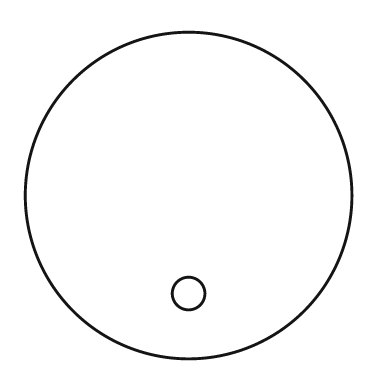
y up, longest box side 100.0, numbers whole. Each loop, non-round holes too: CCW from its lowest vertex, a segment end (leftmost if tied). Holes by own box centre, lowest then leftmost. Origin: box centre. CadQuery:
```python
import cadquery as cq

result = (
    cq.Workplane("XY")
    .moveTo(0.0, 0.0)
    .circle(50.0)
    .moveTo(0.0, -30.0)
    .circle(5.0)
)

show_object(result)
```